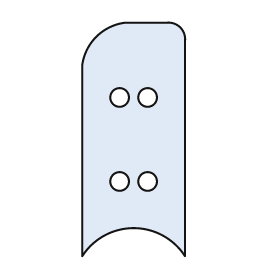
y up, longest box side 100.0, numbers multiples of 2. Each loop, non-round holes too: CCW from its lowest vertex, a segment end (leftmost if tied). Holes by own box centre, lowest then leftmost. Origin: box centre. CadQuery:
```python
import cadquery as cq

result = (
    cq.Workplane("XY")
    .moveTo(-22.0, -50.0)
    .threePointArc((0.0, -38.0), (22.0, -50.0))
    .lineTo(22.0, 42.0)
    .threePointArc((20.0, 48.0), (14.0, 50.0))
    .lineTo(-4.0, 50.0)
    .threePointArc((-16.0, 44.0), (-22.0, 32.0))
    .close()
    .moveTo(-6.0, -18.0)
    .circle(4.0)
    .moveTo(6.0, -18.0)
    .circle(4.0)
    .moveTo(-6.0, 18.0)
    .circle(4.0)
    .moveTo(6.0, 18.0)
    .circle(4.0)
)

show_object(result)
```